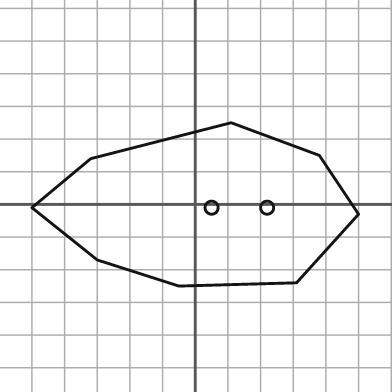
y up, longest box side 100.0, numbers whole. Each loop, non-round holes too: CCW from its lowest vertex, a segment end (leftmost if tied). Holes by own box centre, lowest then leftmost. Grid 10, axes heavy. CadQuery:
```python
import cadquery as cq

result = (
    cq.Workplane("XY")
    .moveTo(-5.0, -25.0)
    .lineTo(31.0, -24.0)
    .lineTo(50.0, -3.0)
    .lineTo(38.0, 15.0)
    .lineTo(11.0, 25.0)
    .lineTo(-32.0, 14.0)
    .lineTo(-50.0, -1.0)
    .lineTo(-30.0, -17.0)
    .close()
    .moveTo(5.0, -1.0)
    .circle(2.0)
    .moveTo(22.0, -1.0)
    .circle(2.0)
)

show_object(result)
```